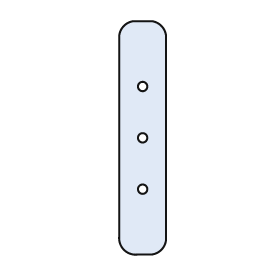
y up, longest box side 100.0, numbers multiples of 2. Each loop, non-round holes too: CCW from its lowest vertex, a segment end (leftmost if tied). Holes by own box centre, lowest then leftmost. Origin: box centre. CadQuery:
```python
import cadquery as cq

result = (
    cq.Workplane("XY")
    .moveTo(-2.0, -50.0)
    .lineTo(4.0, -50.0)
    .threePointArc((8.0, -48.0), (10.0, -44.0))
    .lineTo(10.0, 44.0)
    .threePointArc((8.0, 48.0), (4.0, 50.0))
    .lineTo(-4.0, 50.0)
    .threePointArc((-8.0, 48.0), (-10.0, 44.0))
    .lineTo(-10.0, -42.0)
    .threePointArc((-8.0, -48.0), (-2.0, -50.0))
    .close()
    .moveTo(0.0, -22.0)
    .circle(2.0)
    .moveTo(0.0, 0.0)
    .circle(2.0)
    .moveTo(0.0, 22.0)
    .circle(2.0)
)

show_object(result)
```